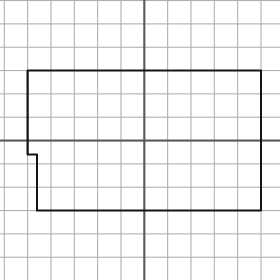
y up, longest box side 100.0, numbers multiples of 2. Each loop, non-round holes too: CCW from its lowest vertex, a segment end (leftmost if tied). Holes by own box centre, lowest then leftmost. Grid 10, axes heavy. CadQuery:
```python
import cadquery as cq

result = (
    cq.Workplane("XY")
    .moveTo(-46.0, -30.0)
    .lineTo(50.0, -30.0)
    .lineTo(50.0, 30.0)
    .lineTo(-50.0, 30.0)
    .lineTo(-50.0, -6.0)
    .lineTo(-46.0, -6.0)
    .close()
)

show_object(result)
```